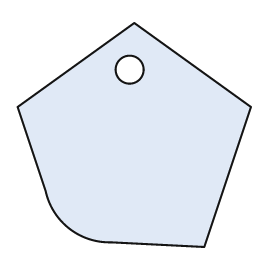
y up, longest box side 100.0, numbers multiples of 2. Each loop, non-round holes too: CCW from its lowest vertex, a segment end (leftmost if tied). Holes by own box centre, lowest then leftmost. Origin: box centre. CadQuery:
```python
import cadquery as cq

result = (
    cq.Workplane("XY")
    .moveTo(30.0, -48.0)
    .lineTo(50.0, 12.0)
    .lineTo(0.0, 48.0)
    .lineTo(-50.0, 12.0)
    .lineTo(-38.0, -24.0)
    .threePointArc((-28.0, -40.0), (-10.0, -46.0))
    .close()
    .moveTo(-2.0, 28.0)
    .circle(6.0)
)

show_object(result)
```